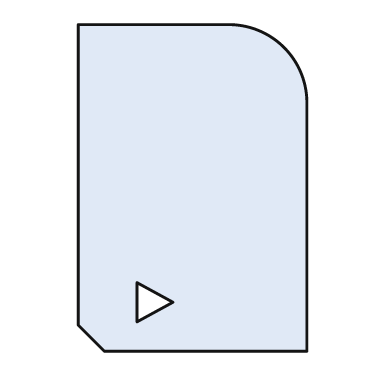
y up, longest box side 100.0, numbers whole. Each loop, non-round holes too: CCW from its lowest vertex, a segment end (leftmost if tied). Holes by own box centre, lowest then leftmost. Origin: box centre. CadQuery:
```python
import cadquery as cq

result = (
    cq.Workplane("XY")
    .moveTo(-27.0, -50.0)
    .lineTo(35.0, -50.0)
    .lineTo(35.0, 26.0)
    .threePointArc((28.0, 43.0), (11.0, 50.0))
    .lineTo(-35.0, 50.0)
    .lineTo(-35.0, -42.0)
    .close()
    .moveTo(-17.0, -41.0)
    .lineTo(-6.0, -35.0)
    .lineTo(-17.0, -29.0)
    .close()
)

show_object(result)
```